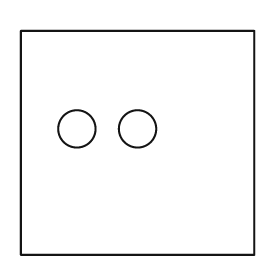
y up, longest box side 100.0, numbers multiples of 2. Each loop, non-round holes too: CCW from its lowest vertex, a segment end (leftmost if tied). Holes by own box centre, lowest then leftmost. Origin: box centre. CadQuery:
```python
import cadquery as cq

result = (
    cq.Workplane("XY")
    .moveTo(-50.0, -48.0)
    .lineTo(50.0, -48.0)
    .lineTo(50.0, 48.0)
    .lineTo(-50.0, 48.0)
    .close()
    .moveTo(-26.0, 6.0)
    .circle(8.0)
    .moveTo(0.0, 6.0)
    .circle(8.0)
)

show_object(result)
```